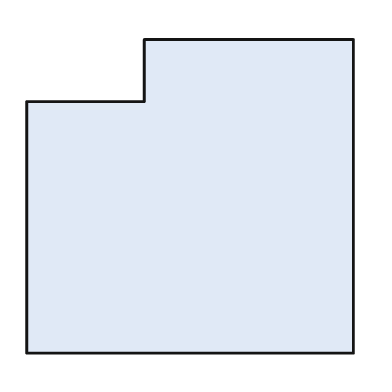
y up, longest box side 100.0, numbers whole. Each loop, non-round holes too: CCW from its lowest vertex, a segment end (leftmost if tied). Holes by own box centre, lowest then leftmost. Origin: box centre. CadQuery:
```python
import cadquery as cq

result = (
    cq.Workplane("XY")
    .moveTo(-50.0, -48.0)
    .lineTo(50.0, -48.0)
    .lineTo(50.0, 48.0)
    .lineTo(-14.0, 48.0)
    .lineTo(-14.0, 29.0)
    .lineTo(-50.0, 29.0)
    .close()
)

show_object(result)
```